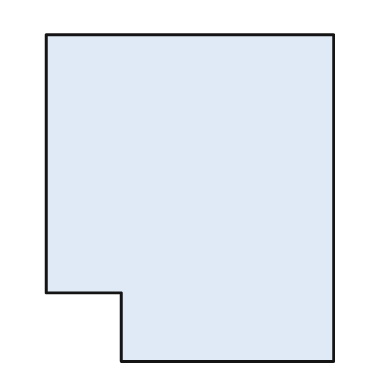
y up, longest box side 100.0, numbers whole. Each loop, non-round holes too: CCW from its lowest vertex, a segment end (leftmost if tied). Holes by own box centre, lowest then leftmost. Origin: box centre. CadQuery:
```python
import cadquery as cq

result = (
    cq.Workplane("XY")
    .moveTo(-21.0, -50.0)
    .lineTo(44.0, -50.0)
    .lineTo(44.0, 50.0)
    .lineTo(-44.0, 50.0)
    .lineTo(-44.0, -29.0)
    .lineTo(-21.0, -29.0)
    .close()
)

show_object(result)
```